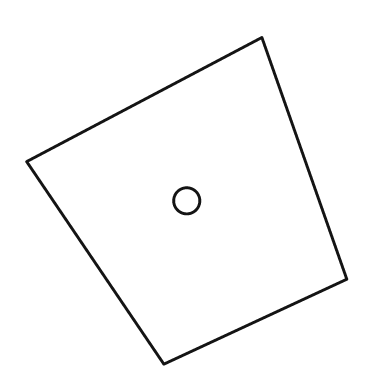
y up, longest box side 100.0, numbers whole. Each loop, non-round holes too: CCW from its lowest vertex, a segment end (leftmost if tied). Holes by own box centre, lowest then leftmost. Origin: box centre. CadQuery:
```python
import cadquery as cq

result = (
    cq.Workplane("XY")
    .moveTo(-7.0, -50.0)
    .lineTo(49.0, -24.0)
    .lineTo(23.0, 50.0)
    .lineTo(-49.0, 12.0)
    .close()
    .moveTo(0.0, 0.0)
    .circle(4.0)
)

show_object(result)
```